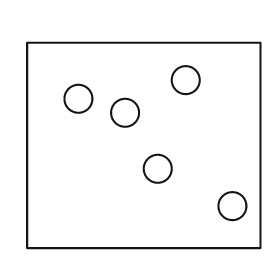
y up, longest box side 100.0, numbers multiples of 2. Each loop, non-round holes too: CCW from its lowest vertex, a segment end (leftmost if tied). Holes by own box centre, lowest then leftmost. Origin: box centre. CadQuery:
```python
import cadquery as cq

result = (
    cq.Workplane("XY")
    .moveTo(-50.0, -44.0)
    .lineTo(50.0, -44.0)
    .lineTo(50.0, 44.0)
    .lineTo(-50.0, 44.0)
    .close()
    .moveTo(38.0, -26.0)
    .circle(6.0)
    .moveTo(6.0, -10.0)
    .circle(6.0)
    .moveTo(-8.0, 14.0)
    .circle(6.0)
    .moveTo(-28.0, 20.0)
    .circle(6.0)
    .moveTo(18.0, 28.0)
    .circle(6.0)
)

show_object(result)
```